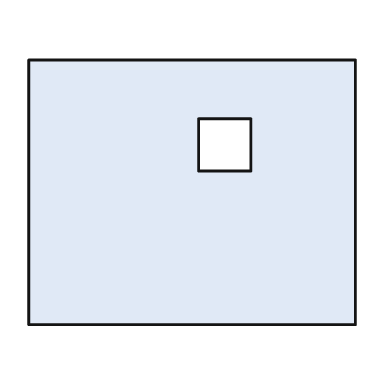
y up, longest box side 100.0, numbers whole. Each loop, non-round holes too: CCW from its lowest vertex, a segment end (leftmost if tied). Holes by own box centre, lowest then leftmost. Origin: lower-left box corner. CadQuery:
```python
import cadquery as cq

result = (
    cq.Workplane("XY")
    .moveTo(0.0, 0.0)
    .lineTo(100.0, 0.0)
    .lineTo(100.0, 81.0)
    .lineTo(0.0, 81.0)
    .close()
    .moveTo(52.0, 47.0)
    .lineTo(68.0, 47.0)
    .lineTo(68.0, 63.0)
    .lineTo(52.0, 63.0)
    .close()
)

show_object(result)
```